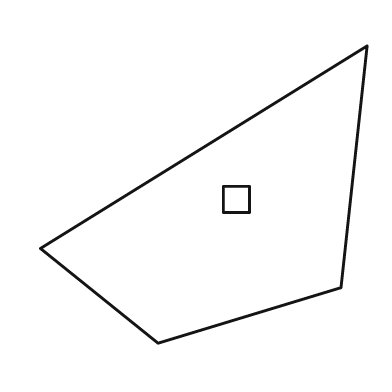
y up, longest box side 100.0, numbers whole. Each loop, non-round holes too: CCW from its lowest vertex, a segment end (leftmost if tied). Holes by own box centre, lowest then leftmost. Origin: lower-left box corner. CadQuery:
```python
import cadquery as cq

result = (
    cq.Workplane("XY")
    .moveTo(36.0, 0.0)
    .lineTo(92.0, 17.0)
    .lineTo(100.0, 91.0)
    .lineTo(0.0, 29.0)
    .close()
    .moveTo(56.0, 40.0)
    .lineTo(64.0, 40.0)
    .lineTo(64.0, 48.0)
    .lineTo(56.0, 48.0)
    .close()
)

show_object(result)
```